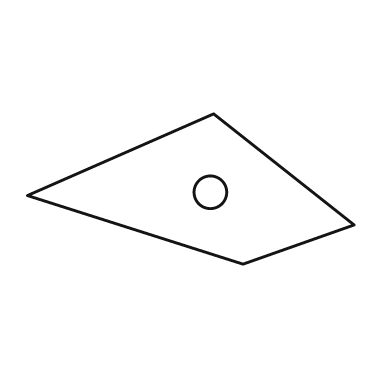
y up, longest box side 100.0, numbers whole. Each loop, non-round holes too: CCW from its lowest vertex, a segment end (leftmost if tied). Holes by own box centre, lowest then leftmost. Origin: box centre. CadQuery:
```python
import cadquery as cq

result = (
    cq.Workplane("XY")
    .moveTo(16.0, -23.0)
    .lineTo(50.0, -11.0)
    .lineTo(7.0, 23.0)
    .lineTo(-50.0, -2.0)
    .close()
    .moveTo(6.0, -1.0)
    .circle(5.0)
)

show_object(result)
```